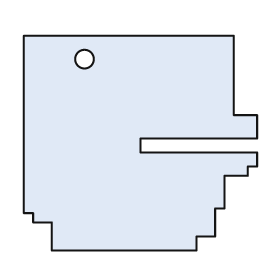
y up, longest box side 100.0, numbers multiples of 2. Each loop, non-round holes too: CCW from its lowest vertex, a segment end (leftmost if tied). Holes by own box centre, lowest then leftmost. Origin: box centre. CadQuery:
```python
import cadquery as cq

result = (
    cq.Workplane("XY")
    .moveTo(-38.0, -46.0)
    .lineTo(24.0, -46.0)
    .lineTo(24.0, -40.0)
    .lineTo(32.0, -40.0)
    .lineTo(32.0, -28.0)
    .lineTo(36.0, -28.0)
    .lineTo(36.0, -14.0)
    .lineTo(46.0, -14.0)
    .lineTo(46.0, -10.0)
    .lineTo(50.0, -10.0)
    .lineTo(50.0, -4.0)
    .lineTo(0.0, -4.0)
    .lineTo(0.0, 2.0)
    .lineTo(50.0, 2.0)
    .lineTo(50.0, 12.0)
    .lineTo(40.0, 12.0)
    .lineTo(40.0, 46.0)
    .lineTo(-50.0, 46.0)
    .lineTo(-50.0, -30.0)
    .lineTo(-46.0, -30.0)
    .lineTo(-46.0, -34.0)
    .lineTo(-38.0, -34.0)
    .close()
    .moveTo(-24.0, 36.0)
    .circle(4.0)
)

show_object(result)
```